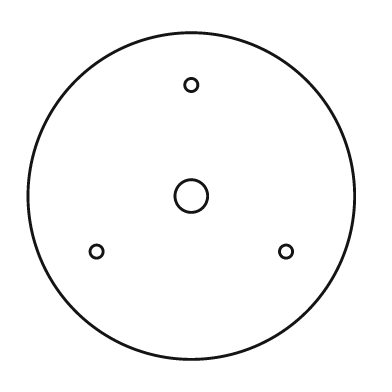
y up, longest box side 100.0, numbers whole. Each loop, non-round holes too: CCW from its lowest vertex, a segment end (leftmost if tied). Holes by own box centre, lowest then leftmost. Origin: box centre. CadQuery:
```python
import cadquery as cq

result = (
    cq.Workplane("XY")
    .moveTo(0.0, 0.0)
    .circle(50.0)
    .moveTo(-29.0, -17.0)
    .circle(2.0)
    .moveTo(29.0, -17.0)
    .circle(2.0)
    .moveTo(0.0, 0.0)
    .circle(5.0)
    .moveTo(0.0, 34.0)
    .circle(2.0)
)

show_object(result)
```